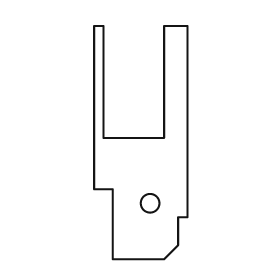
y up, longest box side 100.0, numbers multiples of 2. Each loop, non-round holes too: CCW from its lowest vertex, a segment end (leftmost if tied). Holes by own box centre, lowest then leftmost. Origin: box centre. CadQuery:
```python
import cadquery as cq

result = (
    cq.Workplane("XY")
    .moveTo(-12.0, -50.0)
    .lineTo(10.0, -50.0)
    .lineTo(16.0, -44.0)
    .lineTo(16.0, -32.0)
    .lineTo(20.0, -32.0)
    .lineTo(20.0, 50.0)
    .lineTo(10.0, 50.0)
    .lineTo(10.0, 2.0)
    .lineTo(-16.0, 2.0)
    .lineTo(-16.0, 50.0)
    .lineTo(-20.0, 50.0)
    .lineTo(-20.0, -20.0)
    .lineTo(-12.0, -20.0)
    .close()
    .moveTo(4.0, -26.0)
    .circle(4.0)
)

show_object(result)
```